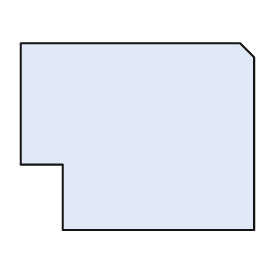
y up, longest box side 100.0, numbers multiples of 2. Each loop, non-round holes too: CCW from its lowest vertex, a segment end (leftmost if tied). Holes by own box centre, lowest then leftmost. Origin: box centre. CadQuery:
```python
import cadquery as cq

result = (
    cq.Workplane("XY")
    .moveTo(-32.0, -40.0)
    .lineTo(50.0, -40.0)
    .lineTo(50.0, 34.0)
    .lineTo(44.0, 40.0)
    .lineTo(-50.0, 40.0)
    .lineTo(-50.0, -12.0)
    .lineTo(-32.0, -12.0)
    .close()
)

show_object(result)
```